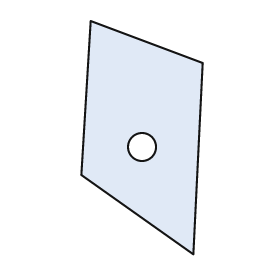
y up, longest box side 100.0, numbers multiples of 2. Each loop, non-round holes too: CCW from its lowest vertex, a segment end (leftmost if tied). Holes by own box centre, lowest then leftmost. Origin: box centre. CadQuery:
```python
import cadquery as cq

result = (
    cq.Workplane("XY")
    .moveTo(22.0, -50.0)
    .lineTo(26.0, 32.0)
    .lineTo(-22.0, 50.0)
    .lineTo(-26.0, -16.0)
    .close()
    .moveTo(0.0, -4.0)
    .circle(6.0)
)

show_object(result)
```